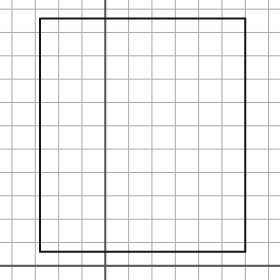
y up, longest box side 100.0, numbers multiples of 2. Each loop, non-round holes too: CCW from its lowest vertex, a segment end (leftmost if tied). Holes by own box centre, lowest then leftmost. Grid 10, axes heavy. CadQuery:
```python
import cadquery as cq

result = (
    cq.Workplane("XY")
    .moveTo(-28.0, 6.0)
    .lineTo(60.0, 6.0)
    .lineTo(60.0, 106.0)
    .lineTo(-28.0, 106.0)
    .close()
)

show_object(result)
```